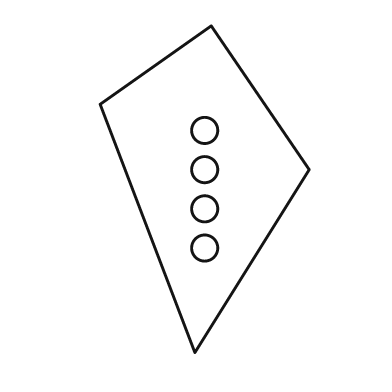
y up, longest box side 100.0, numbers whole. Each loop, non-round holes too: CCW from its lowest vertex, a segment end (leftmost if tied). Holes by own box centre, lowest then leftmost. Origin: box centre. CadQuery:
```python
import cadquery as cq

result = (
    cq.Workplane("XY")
    .moveTo(-3.0, -50.0)
    .lineTo(32.0, 6.0)
    .lineTo(2.0, 50.0)
    .lineTo(-32.0, 26.0)
    .close()
    .moveTo(0.0, -18.0)
    .circle(4.0)
    .moveTo(0.0, -6.0)
    .circle(4.0)
    .moveTo(0.0, 6.0)
    .circle(4.0)
    .moveTo(0.0, 18.0)
    .circle(4.0)
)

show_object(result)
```